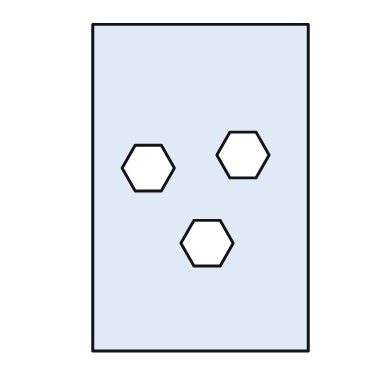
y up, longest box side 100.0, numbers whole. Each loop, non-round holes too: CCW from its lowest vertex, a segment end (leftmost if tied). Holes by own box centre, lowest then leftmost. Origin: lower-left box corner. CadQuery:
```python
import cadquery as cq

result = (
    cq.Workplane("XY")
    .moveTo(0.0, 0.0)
    .lineTo(66.0, 0.0)
    .lineTo(66.0, 100.0)
    .lineTo(0.0, 100.0)
    .close()
    .moveTo(31.0, 26.0)
    .lineTo(39.0, 26.0)
    .lineTo(43.0, 33.0)
    .lineTo(39.0, 40.0)
    .lineTo(31.0, 40.0)
    .lineTo(27.0, 33.0)
    .close()
    .moveTo(13.0, 49.0)
    .lineTo(21.0, 49.0)
    .lineTo(25.0, 56.0)
    .lineTo(21.0, 63.0)
    .lineTo(13.0, 63.0)
    .lineTo(9.0, 56.0)
    .close()
    .moveTo(42.0, 53.0)
    .lineTo(50.0, 53.0)
    .lineTo(54.0, 60.0)
    .lineTo(50.0, 67.0)
    .lineTo(42.0, 67.0)
    .lineTo(38.0, 60.0)
    .close()
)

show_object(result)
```